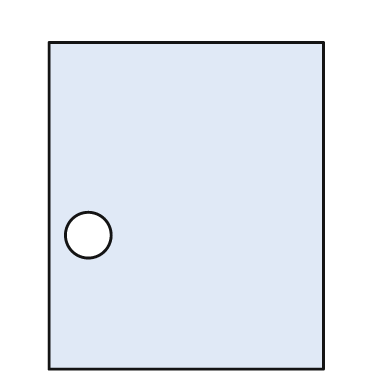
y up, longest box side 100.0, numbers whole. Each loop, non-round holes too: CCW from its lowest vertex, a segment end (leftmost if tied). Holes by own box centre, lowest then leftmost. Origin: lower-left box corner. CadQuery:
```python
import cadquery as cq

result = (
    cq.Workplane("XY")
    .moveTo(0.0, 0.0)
    .lineTo(84.0, 0.0)
    .lineTo(84.0, 100.0)
    .lineTo(0.0, 100.0)
    .close()
    .moveTo(12.0, 41.0)
    .circle(7.0)
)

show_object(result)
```